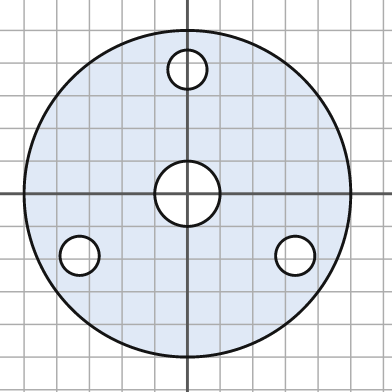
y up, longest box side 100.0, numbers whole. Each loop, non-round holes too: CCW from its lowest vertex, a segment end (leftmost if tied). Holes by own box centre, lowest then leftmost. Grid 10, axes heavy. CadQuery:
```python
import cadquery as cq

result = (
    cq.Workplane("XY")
    .moveTo(0.0, 0.0)
    .circle(50.0)
    .moveTo(-33.0, -19.0)
    .circle(6.0)
    .moveTo(33.0, -19.0)
    .circle(6.0)
    .moveTo(0.0, 0.0)
    .circle(10.0)
    .moveTo(0.0, 38.0)
    .circle(6.0)
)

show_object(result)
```